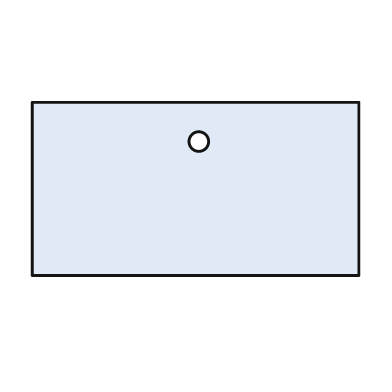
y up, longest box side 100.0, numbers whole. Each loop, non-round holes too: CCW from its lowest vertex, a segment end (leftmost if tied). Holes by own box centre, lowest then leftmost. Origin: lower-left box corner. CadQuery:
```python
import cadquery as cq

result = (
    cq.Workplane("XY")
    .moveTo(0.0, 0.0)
    .lineTo(100.0, 0.0)
    .lineTo(100.0, 53.0)
    .lineTo(0.0, 53.0)
    .close()
    .moveTo(51.0, 41.0)
    .circle(3.0)
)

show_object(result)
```